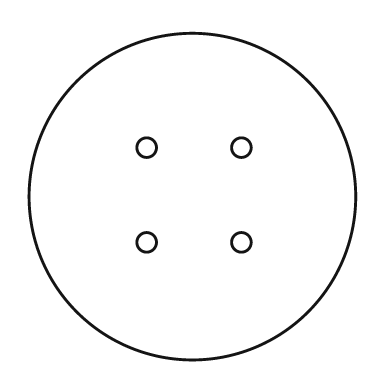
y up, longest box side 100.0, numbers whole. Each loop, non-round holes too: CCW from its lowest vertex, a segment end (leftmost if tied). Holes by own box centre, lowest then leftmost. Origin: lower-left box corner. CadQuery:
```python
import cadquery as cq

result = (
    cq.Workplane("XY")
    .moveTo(50.0, 50.0)
    .circle(50.0)
    .moveTo(36.0, 36.0)
    .circle(3.0)
    .moveTo(65.0, 36.0)
    .circle(3.0)
    .moveTo(36.0, 65.0)
    .circle(3.0)
    .moveTo(65.0, 65.0)
    .circle(3.0)
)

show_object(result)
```